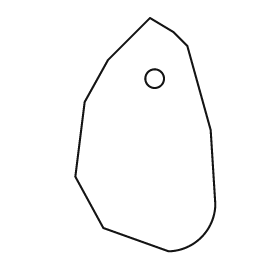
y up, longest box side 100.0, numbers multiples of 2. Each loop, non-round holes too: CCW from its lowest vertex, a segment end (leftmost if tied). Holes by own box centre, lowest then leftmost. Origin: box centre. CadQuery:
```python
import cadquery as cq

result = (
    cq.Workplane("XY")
    .moveTo(10.0, -50.0)
    .threePointArc((24.0, -44.0), (30.0, -30.0))
    .lineTo(28.0, 2.0)
    .lineTo(18.0, 38.0)
    .lineTo(12.0, 44.0)
    .lineTo(2.0, 50.0)
    .lineTo(-16.0, 32.0)
    .lineTo(-26.0, 14.0)
    .lineTo(-30.0, -18.0)
    .lineTo(-18.0, -40.0)
    .close()
    .moveTo(4.0, 24.0)
    .circle(4.0)
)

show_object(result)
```